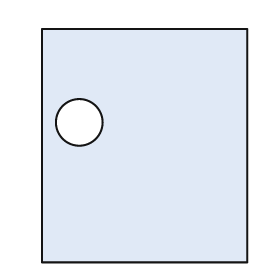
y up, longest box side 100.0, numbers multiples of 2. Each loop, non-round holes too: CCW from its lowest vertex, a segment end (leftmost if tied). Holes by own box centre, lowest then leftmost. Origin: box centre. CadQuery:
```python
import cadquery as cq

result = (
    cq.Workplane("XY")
    .moveTo(-44.0, -50.0)
    .lineTo(44.0, -50.0)
    .lineTo(44.0, 50.0)
    .lineTo(-44.0, 50.0)
    .close()
    .moveTo(-28.0, 10.0)
    .circle(10.0)
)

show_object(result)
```